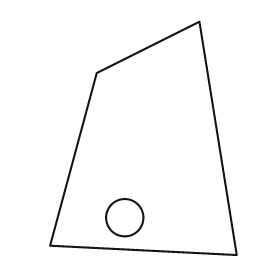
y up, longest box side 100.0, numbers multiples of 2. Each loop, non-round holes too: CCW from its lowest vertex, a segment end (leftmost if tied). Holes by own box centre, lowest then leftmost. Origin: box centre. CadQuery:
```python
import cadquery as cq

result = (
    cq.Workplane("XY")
    .moveTo(40.0, -50.0)
    .lineTo(24.0, 50.0)
    .lineTo(-20.0, 28.0)
    .lineTo(-40.0, -46.0)
    .close()
    .moveTo(-8.0, -34.0)
    .circle(8.0)
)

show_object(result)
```